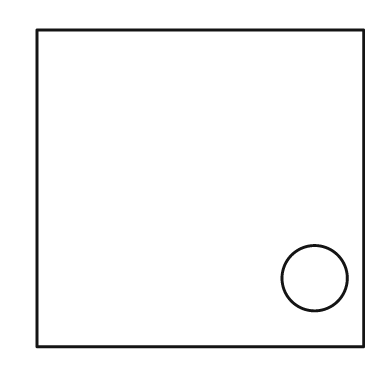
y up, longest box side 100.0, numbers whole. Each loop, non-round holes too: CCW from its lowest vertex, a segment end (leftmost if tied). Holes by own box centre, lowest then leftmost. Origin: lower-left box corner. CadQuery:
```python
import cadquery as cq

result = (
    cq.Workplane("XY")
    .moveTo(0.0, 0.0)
    .lineTo(100.0, 0.0)
    .lineTo(100.0, 97.0)
    .lineTo(0.0, 97.0)
    .close()
    .moveTo(85.0, 21.0)
    .circle(10.0)
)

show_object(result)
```